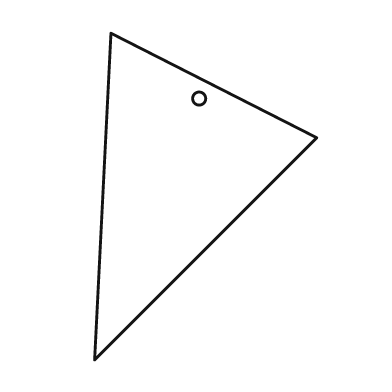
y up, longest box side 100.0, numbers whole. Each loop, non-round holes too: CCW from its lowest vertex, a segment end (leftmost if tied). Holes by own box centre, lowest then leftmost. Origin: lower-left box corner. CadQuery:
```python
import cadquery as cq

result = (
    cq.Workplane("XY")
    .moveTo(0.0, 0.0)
    .lineTo(68.0, 68.0)
    .lineTo(5.0, 100.0)
    .close()
    .moveTo(32.0, 80.0)
    .circle(2.0)
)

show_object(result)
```